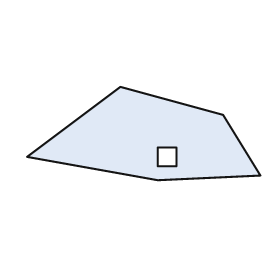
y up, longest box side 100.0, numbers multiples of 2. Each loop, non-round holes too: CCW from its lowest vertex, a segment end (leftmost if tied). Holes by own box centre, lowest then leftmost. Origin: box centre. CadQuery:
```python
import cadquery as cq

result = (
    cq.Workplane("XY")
    .moveTo(6.0, -20.0)
    .lineTo(50.0, -18.0)
    .lineTo(34.0, 8.0)
    .lineTo(-10.0, 20.0)
    .lineTo(-50.0, -10.0)
    .close()
    .moveTo(6.0, -14.0)
    .lineTo(14.0, -14.0)
    .lineTo(14.0, -6.0)
    .lineTo(6.0, -6.0)
    .close()
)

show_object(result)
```